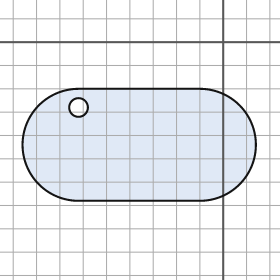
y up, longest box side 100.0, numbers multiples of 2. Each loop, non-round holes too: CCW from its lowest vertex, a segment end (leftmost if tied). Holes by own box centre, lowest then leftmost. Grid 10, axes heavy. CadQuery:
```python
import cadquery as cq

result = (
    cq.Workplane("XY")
    .moveTo(-62.0, -68.0)
    .lineTo(-10.0, -68.0)
    .threePointArc((14.0, -44.0), (-10.0, -20.0))
    .lineTo(-62.0, -20.0)
    .threePointArc((-86.0, -44.0), (-62.0, -68.0))
    .close()
    .moveTo(-62.0, -28.0)
    .circle(4.0)
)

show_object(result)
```